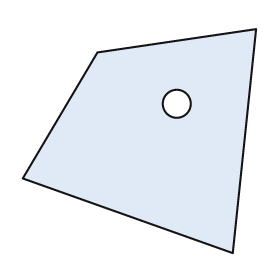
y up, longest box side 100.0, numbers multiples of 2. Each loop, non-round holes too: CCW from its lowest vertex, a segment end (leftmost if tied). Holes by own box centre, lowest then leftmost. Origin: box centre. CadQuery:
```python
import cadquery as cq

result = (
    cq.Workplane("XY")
    .moveTo(40.0, -48.0)
    .lineTo(50.0, 48.0)
    .lineTo(-18.0, 38.0)
    .lineTo(-50.0, -16.0)
    .close()
    .moveTo(16.0, 16.0)
    .circle(6.0)
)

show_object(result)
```